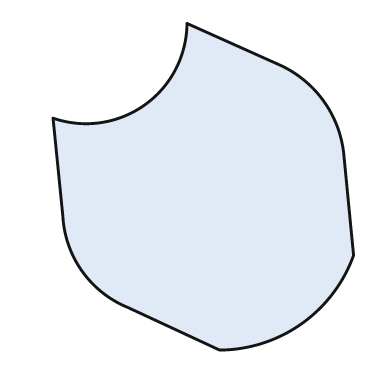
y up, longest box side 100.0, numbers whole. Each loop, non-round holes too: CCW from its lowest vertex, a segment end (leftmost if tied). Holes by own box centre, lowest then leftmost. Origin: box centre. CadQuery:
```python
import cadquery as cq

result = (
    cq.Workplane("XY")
    .moveTo(5.0, -50.0)
    .threePointArc((30.0, -42.0), (46.0, -21.0))
    .lineTo(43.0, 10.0)
    .threePointArc((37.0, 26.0), (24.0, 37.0))
    .lineTo(-5.0, 50.0)
    .threePointArc((-18.0, 25.0), (-46.0, 21.0))
    .lineTo(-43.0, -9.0)
    .threePointArc((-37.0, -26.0), (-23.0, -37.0))
    .close()
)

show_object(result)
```